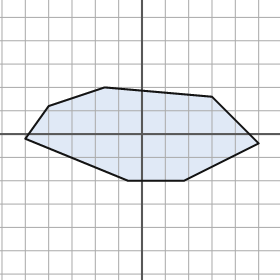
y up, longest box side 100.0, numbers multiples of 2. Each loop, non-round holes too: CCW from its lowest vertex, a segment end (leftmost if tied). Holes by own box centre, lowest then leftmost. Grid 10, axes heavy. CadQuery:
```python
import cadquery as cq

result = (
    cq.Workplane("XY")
    .moveTo(-6.0, -20.0)
    .lineTo(18.0, -20.0)
    .lineTo(50.0, -4.0)
    .lineTo(30.0, 16.0)
    .lineTo(-16.0, 20.0)
    .lineTo(-40.0, 12.0)
    .lineTo(-50.0, -2.0)
    .close()
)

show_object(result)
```